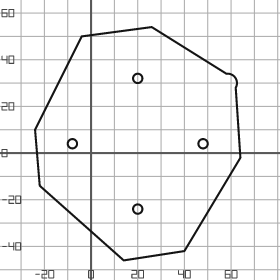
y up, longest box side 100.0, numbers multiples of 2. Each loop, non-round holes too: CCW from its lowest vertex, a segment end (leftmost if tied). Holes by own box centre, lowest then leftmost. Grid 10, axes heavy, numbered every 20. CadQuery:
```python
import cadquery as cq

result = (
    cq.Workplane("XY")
    .moveTo(14.0, -46.0)
    .lineTo(40.0, -42.0)
    .lineTo(64.0, -2.0)
    .lineTo(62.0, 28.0)
    .threePointArc((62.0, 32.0), (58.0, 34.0))
    .lineTo(26.0, 54.0)
    .lineTo(-4.0, 50.0)
    .lineTo(-24.0, 10.0)
    .lineTo(-22.0, -14.0)
    .close()
    .moveTo(20.0, -24.0)
    .circle(2.0)
    .moveTo(-8.0, 4.0)
    .circle(2.0)
    .moveTo(48.0, 4.0)
    .circle(2.0)
    .moveTo(20.0, 32.0)
    .circle(2.0)
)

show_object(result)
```